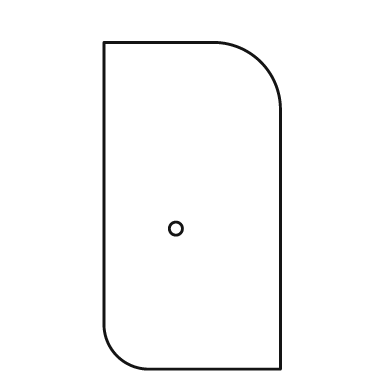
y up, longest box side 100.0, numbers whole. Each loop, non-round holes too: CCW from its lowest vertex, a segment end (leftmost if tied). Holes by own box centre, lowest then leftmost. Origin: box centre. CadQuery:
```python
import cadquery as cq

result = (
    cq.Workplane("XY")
    .moveTo(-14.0, -50.0)
    .lineTo(27.0, -50.0)
    .lineTo(27.0, 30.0)
    .threePointArc((21.0, 44.0), (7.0, 50.0))
    .lineTo(-27.0, 50.0)
    .lineTo(-27.0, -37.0)
    .threePointArc((-23.0, -46.0), (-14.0, -50.0))
    .close()
    .moveTo(-5.0, -7.0)
    .circle(2.0)
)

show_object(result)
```